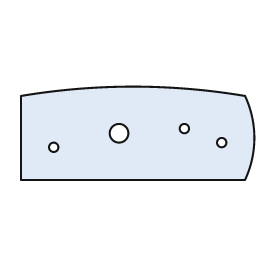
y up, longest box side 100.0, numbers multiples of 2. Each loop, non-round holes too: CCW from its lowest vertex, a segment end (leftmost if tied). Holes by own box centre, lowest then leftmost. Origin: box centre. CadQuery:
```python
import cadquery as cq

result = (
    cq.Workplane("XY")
    .moveTo(-50.0, -20.0)
    .lineTo(46.0, -20.0)
    .threePointArc((50.0, -2.0), (46.0, 16.0))
    .threePointArc((-2.0, 20.0), (-50.0, 16.0))
    .close()
    .moveTo(-36.0, -6.0)
    .circle(2.0)
    .moveTo(36.0, -4.0)
    .circle(2.0)
    .moveTo(-8.0, 0.0)
    .circle(4.0)
    .moveTo(20.0, 2.0)
    .circle(2.0)
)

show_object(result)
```